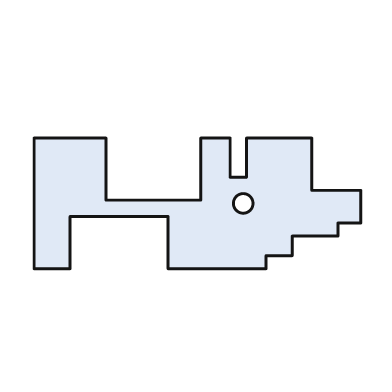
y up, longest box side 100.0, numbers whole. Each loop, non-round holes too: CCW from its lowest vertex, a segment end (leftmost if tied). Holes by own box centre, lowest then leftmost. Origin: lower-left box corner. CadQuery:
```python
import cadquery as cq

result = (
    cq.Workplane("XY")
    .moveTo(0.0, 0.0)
    .lineTo(11.0, 0.0)
    .lineTo(11.0, 16.0)
    .lineTo(41.0, 16.0)
    .lineTo(41.0, 0.0)
    .lineTo(71.0, 0.0)
    .lineTo(71.0, 4.0)
    .lineTo(79.0, 4.0)
    .lineTo(79.0, 10.0)
    .lineTo(93.0, 10.0)
    .lineTo(93.0, 14.0)
    .lineTo(100.0, 14.0)
    .lineTo(100.0, 24.0)
    .lineTo(85.0, 24.0)
    .lineTo(85.0, 40.0)
    .lineTo(65.0, 40.0)
    .lineTo(65.0, 28.0)
    .lineTo(60.0, 28.0)
    .lineTo(60.0, 40.0)
    .lineTo(51.0, 40.0)
    .lineTo(51.0, 21.0)
    .lineTo(22.0, 21.0)
    .lineTo(22.0, 40.0)
    .lineTo(0.0, 40.0)
    .close()
    .moveTo(64.0, 20.0)
    .circle(3.0)
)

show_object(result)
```